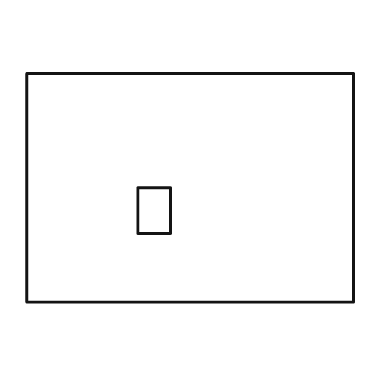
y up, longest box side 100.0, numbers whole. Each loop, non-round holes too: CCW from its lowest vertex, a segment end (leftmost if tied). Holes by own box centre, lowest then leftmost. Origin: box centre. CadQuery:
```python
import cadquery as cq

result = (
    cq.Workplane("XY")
    .moveTo(-50.0, -35.0)
    .lineTo(50.0, -35.0)
    .lineTo(50.0, 35.0)
    .lineTo(-50.0, 35.0)
    .close()
    .moveTo(-16.0, -14.0)
    .lineTo(-6.0, -14.0)
    .lineTo(-6.0, 0.0)
    .lineTo(-16.0, 0.0)
    .close()
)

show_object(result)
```